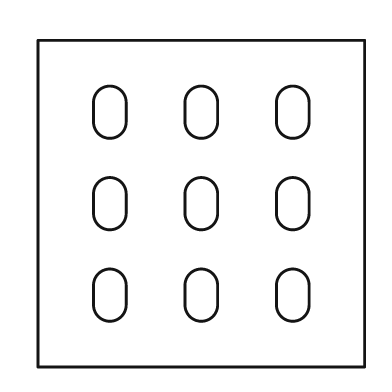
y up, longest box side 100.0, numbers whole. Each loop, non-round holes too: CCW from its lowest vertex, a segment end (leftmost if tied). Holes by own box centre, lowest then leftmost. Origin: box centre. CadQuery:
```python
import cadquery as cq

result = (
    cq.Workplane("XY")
    .moveTo(-50.0, -50.0)
    .lineTo(50.0, -50.0)
    .lineTo(50.0, 50.0)
    .lineTo(-50.0, 50.0)
    .close()
    .moveTo(-33.0, -31.0)
    .threePointArc((-28.0, -36.0), (-23.0, -31.0))
    .lineTo(-23.0, -25.0)
    .threePointArc((-28.0, -20.0), (-33.0, -25.0))
    .close()
    .moveTo(-5.0, -31.0)
    .threePointArc((0.0, -36.0), (5.0, -31.0))
    .lineTo(5.0, -25.0)
    .threePointArc((0.0, -20.0), (-5.0, -25.0))
    .close()
    .moveTo(23.0, -31.0)
    .threePointArc((28.0, -36.0), (33.0, -31.0))
    .lineTo(33.0, -25.0)
    .threePointArc((28.0, -20.0), (23.0, -25.0))
    .close()
    .moveTo(-33.0, -3.0)
    .threePointArc((-28.0, -8.0), (-23.0, -3.0))
    .lineTo(-23.0, 3.0)
    .threePointArc((-28.0, 8.0), (-33.0, 3.0))
    .close()
    .moveTo(-5.0, -3.0)
    .threePointArc((0.0, -8.0), (5.0, -3.0))
    .lineTo(5.0, 3.0)
    .threePointArc((0.0, 8.0), (-5.0, 3.0))
    .close()
    .moveTo(23.0, -3.0)
    .threePointArc((28.0, -8.0), (33.0, -3.0))
    .lineTo(33.0, 3.0)
    .threePointArc((28.0, 8.0), (23.0, 3.0))
    .close()
    .moveTo(-33.0, 25.0)
    .threePointArc((-28.0, 20.0), (-23.0, 25.0))
    .lineTo(-23.0, 31.0)
    .threePointArc((-28.0, 36.0), (-33.0, 31.0))
    .close()
    .moveTo(-5.0, 25.0)
    .threePointArc((0.0, 20.0), (5.0, 25.0))
    .lineTo(5.0, 31.0)
    .threePointArc((0.0, 36.0), (-5.0, 31.0))
    .close()
    .moveTo(23.0, 25.0)
    .threePointArc((28.0, 20.0), (33.0, 25.0))
    .lineTo(33.0, 31.0)
    .threePointArc((28.0, 36.0), (23.0, 31.0))
    .close()
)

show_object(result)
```